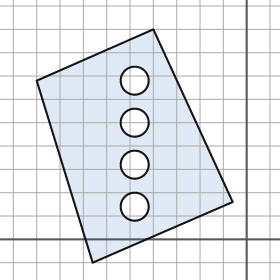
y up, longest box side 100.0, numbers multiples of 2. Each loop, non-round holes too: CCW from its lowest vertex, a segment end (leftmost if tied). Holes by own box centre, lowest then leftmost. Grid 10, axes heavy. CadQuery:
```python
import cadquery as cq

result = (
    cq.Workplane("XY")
    .moveTo(-66.0, -10.0)
    .lineTo(-6.0, 16.0)
    .lineTo(-40.0, 90.0)
    .lineTo(-90.0, 68.0)
    .close()
    .moveTo(-48.0, 14.0)
    .circle(6.0)
    .moveTo(-48.0, 32.0)
    .circle(6.0)
    .moveTo(-48.0, 50.0)
    .circle(6.0)
    .moveTo(-48.0, 68.0)
    .circle(6.0)
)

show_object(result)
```